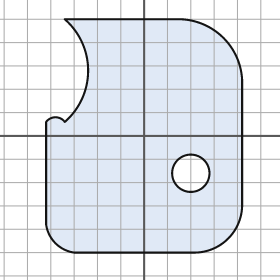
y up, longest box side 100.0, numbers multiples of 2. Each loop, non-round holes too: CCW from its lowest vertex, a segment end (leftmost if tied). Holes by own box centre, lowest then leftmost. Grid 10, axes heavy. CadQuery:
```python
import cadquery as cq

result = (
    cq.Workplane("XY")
    .moveTo(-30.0, -50.0)
    .lineTo(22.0, -50.0)
    .threePointArc((36.0, -44.0), (42.0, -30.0))
    .lineTo(42.0, 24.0)
    .threePointArc((34.0, 42.0), (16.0, 50.0))
    .lineTo(-34.0, 50.0)
    .threePointArc((-24.0, 28.0), (-34.0, 6.0))
    .threePointArc((-38.0, 8.0), (-42.0, 6.0))
    .lineTo(-42.0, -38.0)
    .threePointArc((-38.0, -46.0), (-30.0, -50.0))
    .close()
    .moveTo(20.0, -16.0)
    .circle(8.0)
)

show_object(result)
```